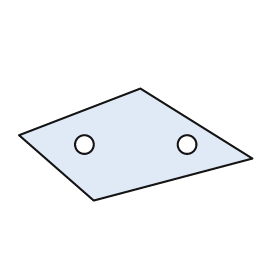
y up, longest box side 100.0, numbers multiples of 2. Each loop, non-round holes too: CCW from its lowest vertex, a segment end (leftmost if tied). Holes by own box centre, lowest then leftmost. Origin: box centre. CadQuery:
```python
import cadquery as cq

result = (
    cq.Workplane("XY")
    .moveTo(-18.0, -24.0)
    .lineTo(50.0, -6.0)
    .lineTo(2.0, 24.0)
    .lineTo(-50.0, 4.0)
    .close()
    .moveTo(-22.0, 0.0)
    .circle(4.0)
    .moveTo(22.0, 0.0)
    .circle(4.0)
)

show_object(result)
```